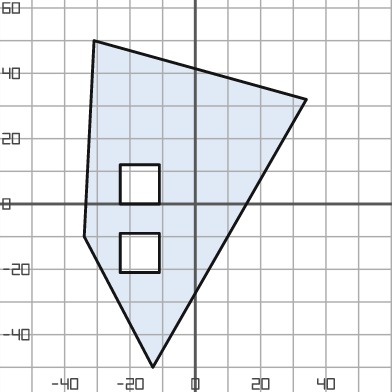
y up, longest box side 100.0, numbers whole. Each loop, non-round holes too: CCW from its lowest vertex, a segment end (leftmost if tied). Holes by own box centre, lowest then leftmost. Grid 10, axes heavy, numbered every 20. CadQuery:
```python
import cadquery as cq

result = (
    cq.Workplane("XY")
    .moveTo(-13.0, -50.0)
    .lineTo(34.0, 32.0)
    .lineTo(-31.0, 50.0)
    .lineTo(-34.0, -10.0)
    .close()
    .moveTo(-23.0, -21.0)
    .lineTo(-11.0, -21.0)
    .lineTo(-11.0, -9.0)
    .lineTo(-23.0, -9.0)
    .close()
    .moveTo(-23.0, 0.0)
    .lineTo(-11.0, 0.0)
    .lineTo(-11.0, 12.0)
    .lineTo(-23.0, 12.0)
    .close()
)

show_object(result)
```